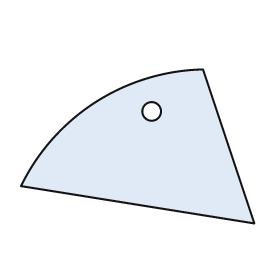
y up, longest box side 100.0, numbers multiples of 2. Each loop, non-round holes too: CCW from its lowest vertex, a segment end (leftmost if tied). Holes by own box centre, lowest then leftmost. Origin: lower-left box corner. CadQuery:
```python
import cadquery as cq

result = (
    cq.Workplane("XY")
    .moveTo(100.0, 0.0)
    .lineTo(78.0, 66.0)
    .threePointArc((32.0, 52.0), (0.0, 16.0))
    .close()
    .moveTo(56.0, 48.0)
    .circle(4.0)
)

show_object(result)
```